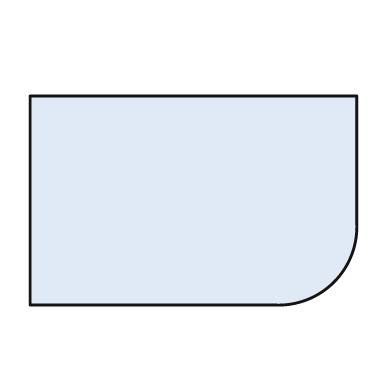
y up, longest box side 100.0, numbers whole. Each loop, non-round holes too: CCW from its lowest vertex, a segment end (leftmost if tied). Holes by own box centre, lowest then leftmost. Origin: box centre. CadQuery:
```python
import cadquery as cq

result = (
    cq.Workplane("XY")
    .moveTo(-50.0, -32.0)
    .lineTo(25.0, -32.0)
    .threePointArc((43.0, -25.0), (50.0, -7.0))
    .lineTo(50.0, 32.0)
    .lineTo(-50.0, 32.0)
    .close()
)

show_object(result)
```